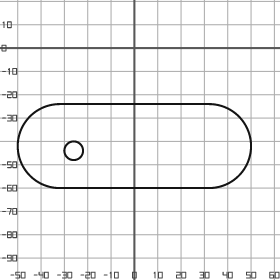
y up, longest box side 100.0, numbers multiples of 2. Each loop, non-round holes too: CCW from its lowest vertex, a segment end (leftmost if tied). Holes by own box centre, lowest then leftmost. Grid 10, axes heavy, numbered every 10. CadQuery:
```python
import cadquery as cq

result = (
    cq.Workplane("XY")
    .moveTo(-32.0, -60.0)
    .lineTo(32.0, -60.0)
    .threePointArc((50.0, -42.0), (32.0, -24.0))
    .lineTo(-32.0, -24.0)
    .threePointArc((-50.0, -42.0), (-32.0, -60.0))
    .close()
    .moveTo(-26.0, -44.0)
    .circle(4.0)
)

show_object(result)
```